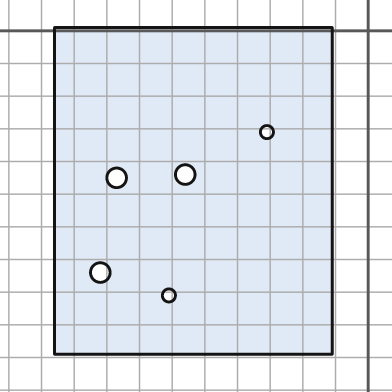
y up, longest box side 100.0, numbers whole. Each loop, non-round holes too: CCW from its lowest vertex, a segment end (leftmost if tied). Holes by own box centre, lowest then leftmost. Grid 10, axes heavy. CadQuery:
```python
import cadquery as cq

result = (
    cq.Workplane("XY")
    .moveTo(-96.0, -99.0)
    .lineTo(-11.0, -99.0)
    .lineTo(-11.0, 1.0)
    .lineTo(-96.0, 1.0)
    .close()
    .moveTo(-61.0, -81.0)
    .circle(2.0)
    .moveTo(-82.0, -74.0)
    .circle(3.0)
    .moveTo(-77.0, -45.0)
    .circle(3.0)
    .moveTo(-56.0, -44.0)
    .circle(3.0)
    .moveTo(-31.0, -31.0)
    .circle(2.0)
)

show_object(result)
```